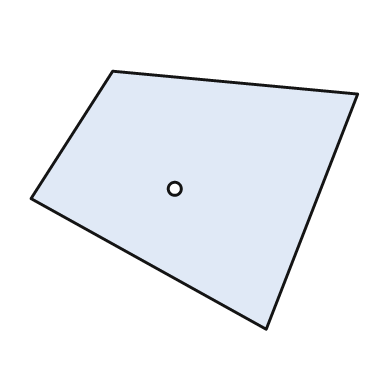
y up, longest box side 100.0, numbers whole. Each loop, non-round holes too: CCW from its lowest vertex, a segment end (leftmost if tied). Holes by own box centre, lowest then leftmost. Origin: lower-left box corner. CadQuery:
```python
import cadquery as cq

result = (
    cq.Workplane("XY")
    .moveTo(72.0, 0.0)
    .lineTo(100.0, 72.0)
    .lineTo(25.0, 79.0)
    .lineTo(0.0, 40.0)
    .close()
    .moveTo(44.0, 43.0)
    .circle(2.0)
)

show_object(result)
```